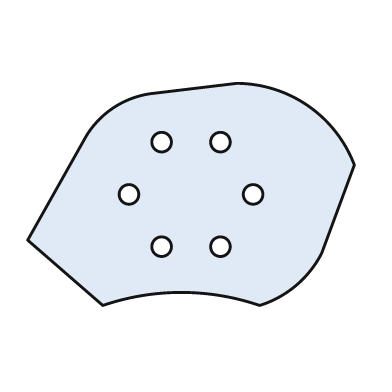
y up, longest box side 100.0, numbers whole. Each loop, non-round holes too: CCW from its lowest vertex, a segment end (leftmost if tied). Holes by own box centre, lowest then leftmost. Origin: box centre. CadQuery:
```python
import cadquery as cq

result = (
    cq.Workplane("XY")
    .moveTo(-27.0, -34.0)
    .threePointArc((-3.0, -30.0), (21.0, -34.0))
    .threePointArc((32.0, -28.0), (40.0, -18.0))
    .lineTo(50.0, 9.0)
    .threePointArc((36.0, 27.0), (14.0, 34.0))
    .lineTo(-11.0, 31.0)
    .threePointArc((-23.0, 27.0), (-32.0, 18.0))
    .lineTo(-50.0, -14.0)
    .close()
    .moveTo(-9.0, -16.0)
    .circle(3.0)
    .moveTo(9.0, -16.0)
    .circle(3.0)
    .moveTo(-19.0, 0.0)
    .circle(3.0)
    .moveTo(19.0, 0.0)
    .circle(3.0)
    .moveTo(-9.0, 16.0)
    .circle(3.0)
    .moveTo(9.0, 16.0)
    .circle(3.0)
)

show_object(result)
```